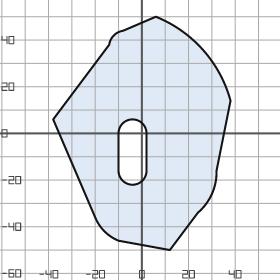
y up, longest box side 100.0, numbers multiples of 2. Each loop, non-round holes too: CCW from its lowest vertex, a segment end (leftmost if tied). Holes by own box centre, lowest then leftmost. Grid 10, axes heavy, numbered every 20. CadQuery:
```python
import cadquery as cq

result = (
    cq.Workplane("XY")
    .moveTo(12.0, -50.0)
    .lineTo(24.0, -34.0)
    .threePointArc((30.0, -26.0), (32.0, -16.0))
    .lineTo(38.0, 14.0)
    .threePointArc((26.0, 36.0), (6.0, 50.0))
    .lineTo(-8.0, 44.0)
    .threePointArc((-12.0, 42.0), (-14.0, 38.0))
    .lineTo(-38.0, 6.0)
    .lineTo(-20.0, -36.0)
    .threePointArc((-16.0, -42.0), (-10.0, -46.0))
    .close()
    .moveTo(-10.0, -16.0)
    .threePointArc((-4.0, -22.0), (2.0, -16.0))
    .lineTo(2.0, 0.0)
    .threePointArc((-4.0, 6.0), (-10.0, 0.0))
    .close()
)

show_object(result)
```